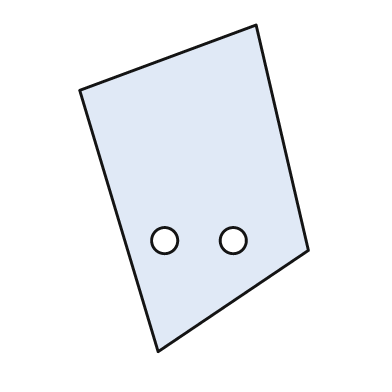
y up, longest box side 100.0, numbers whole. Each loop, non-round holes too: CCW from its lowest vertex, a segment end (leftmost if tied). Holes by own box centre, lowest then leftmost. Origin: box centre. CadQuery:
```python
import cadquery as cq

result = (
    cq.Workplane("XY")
    .moveTo(-11.0, -50.0)
    .lineTo(35.0, -19.0)
    .lineTo(19.0, 50.0)
    .lineTo(-35.0, 30.0)
    .close()
    .moveTo(-9.0, -16.0)
    .circle(4.0)
    .moveTo(12.0, -16.0)
    .circle(4.0)
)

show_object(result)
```